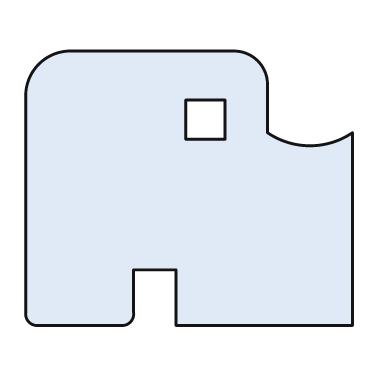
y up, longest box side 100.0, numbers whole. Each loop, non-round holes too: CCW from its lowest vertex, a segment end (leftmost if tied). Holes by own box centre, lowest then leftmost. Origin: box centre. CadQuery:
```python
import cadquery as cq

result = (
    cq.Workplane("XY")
    .moveTo(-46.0, -42.0)
    .lineTo(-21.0, -42.0)
    .threePointArc((-18.0, -41.0), (-17.0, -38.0))
    .lineTo(-17.0, -25.0)
    .lineTo(-4.0, -25.0)
    .lineTo(-4.0, -42.0)
    .lineTo(50.0, -42.0)
    .lineTo(50.0, 17.0)
    .threePointArc((37.0, 13.0), (24.0, 17.0))
    .lineTo(24.0, 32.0)
    .threePointArc((21.0, 39.0), (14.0, 42.0))
    .lineTo(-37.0, 42.0)
    .threePointArc((-46.0, 38.0), (-50.0, 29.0))
    .lineTo(-50.0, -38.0)
    .threePointArc((-49.0, -41.0), (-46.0, -42.0))
    .close()
    .moveTo(-1.0, 15.0)
    .lineTo(11.0, 15.0)
    .lineTo(11.0, 27.0)
    .lineTo(-1.0, 27.0)
    .close()
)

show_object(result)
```